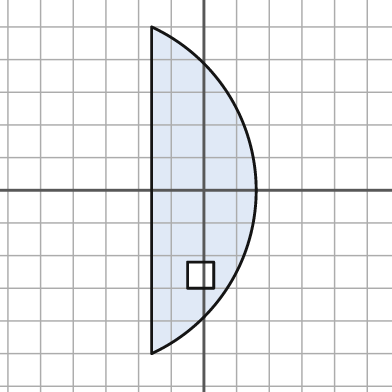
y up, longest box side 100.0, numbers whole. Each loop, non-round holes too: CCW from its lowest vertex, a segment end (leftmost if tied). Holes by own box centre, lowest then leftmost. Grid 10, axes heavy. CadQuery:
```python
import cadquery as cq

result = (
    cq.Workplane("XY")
    .moveTo(-16.0, -50.0)
    .threePointArc((16.0, 0.0), (-16.0, 50.0))
    .close()
    .moveTo(-5.0, -30.0)
    .lineTo(3.0, -30.0)
    .lineTo(3.0, -22.0)
    .lineTo(-5.0, -22.0)
    .close()
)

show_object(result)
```